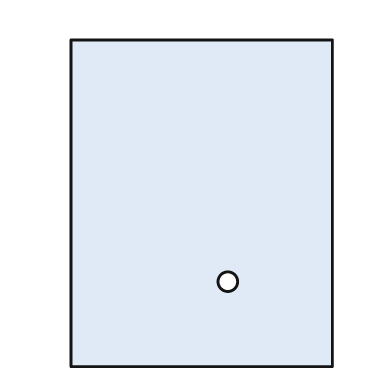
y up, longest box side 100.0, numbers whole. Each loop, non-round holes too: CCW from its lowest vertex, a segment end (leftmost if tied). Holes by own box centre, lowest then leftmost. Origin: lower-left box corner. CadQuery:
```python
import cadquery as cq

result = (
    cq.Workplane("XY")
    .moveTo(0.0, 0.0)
    .lineTo(80.0, 0.0)
    .lineTo(80.0, 100.0)
    .lineTo(0.0, 100.0)
    .close()
    .moveTo(48.0, 26.0)
    .circle(3.0)
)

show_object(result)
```